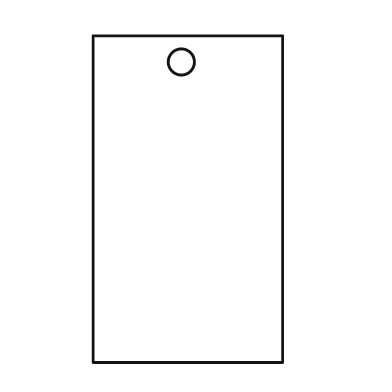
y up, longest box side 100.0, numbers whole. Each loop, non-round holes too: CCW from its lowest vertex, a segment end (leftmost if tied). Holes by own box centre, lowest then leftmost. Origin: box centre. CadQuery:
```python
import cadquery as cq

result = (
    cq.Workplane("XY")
    .moveTo(-29.0, -50.0)
    .lineTo(29.0, -50.0)
    .lineTo(29.0, 50.0)
    .lineTo(-29.0, 50.0)
    .close()
    .moveTo(-2.0, 42.0)
    .circle(4.0)
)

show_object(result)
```